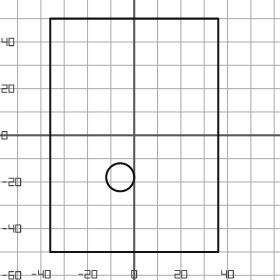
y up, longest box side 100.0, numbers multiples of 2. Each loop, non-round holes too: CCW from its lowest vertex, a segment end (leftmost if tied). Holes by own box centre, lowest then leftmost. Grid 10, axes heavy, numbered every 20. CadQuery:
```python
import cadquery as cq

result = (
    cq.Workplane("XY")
    .moveTo(-36.0, -50.0)
    .lineTo(36.0, -50.0)
    .lineTo(36.0, 50.0)
    .lineTo(-36.0, 50.0)
    .close()
    .moveTo(-6.0, -18.0)
    .circle(6.0)
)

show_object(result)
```